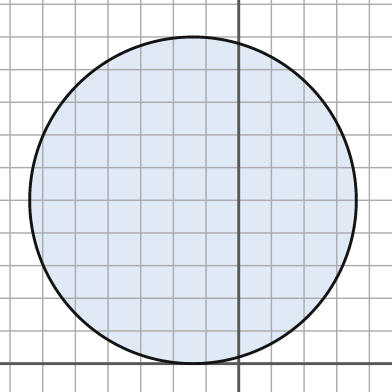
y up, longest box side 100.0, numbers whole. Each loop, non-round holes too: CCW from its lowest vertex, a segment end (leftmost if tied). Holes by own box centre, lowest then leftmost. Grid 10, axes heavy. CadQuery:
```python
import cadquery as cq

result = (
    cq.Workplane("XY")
    .moveTo(-14.0, 50.0)
    .circle(50.0)
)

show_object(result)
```